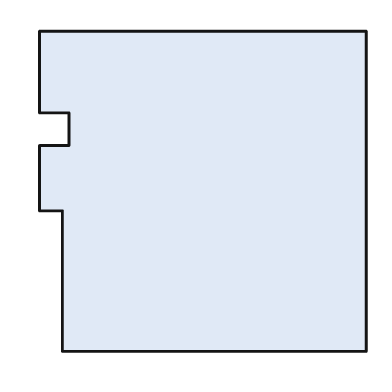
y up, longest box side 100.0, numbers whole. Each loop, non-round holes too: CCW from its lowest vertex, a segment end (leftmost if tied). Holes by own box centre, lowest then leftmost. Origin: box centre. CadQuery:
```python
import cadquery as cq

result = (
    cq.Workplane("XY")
    .moveTo(-43.0, -49.0)
    .lineTo(50.0, -49.0)
    .lineTo(50.0, 49.0)
    .lineTo(-50.0, 49.0)
    .lineTo(-50.0, 24.0)
    .lineTo(-41.0, 24.0)
    .lineTo(-41.0, 14.0)
    .lineTo(-50.0, 14.0)
    .lineTo(-50.0, -6.0)
    .lineTo(-43.0, -6.0)
    .close()
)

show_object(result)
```